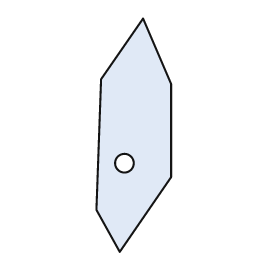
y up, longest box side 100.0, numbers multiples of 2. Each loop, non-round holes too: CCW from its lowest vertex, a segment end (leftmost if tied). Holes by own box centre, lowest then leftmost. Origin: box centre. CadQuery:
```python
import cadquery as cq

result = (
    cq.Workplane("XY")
    .moveTo(-6.0, -50.0)
    .lineTo(16.0, -18.0)
    .lineTo(16.0, 22.0)
    .lineTo(4.0, 50.0)
    .lineTo(-14.0, 24.0)
    .lineTo(-16.0, -32.0)
    .close()
    .moveTo(-4.0, -12.0)
    .circle(4.0)
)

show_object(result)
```